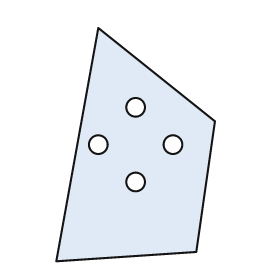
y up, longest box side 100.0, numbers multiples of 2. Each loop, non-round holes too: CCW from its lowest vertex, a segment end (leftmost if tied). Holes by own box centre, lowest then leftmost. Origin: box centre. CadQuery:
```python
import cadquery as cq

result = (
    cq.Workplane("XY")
    .moveTo(-34.0, -50.0)
    .lineTo(26.0, -46.0)
    .lineTo(34.0, 10.0)
    .lineTo(-16.0, 50.0)
    .close()
    .moveTo(0.0, -16.0)
    .circle(4.0)
    .moveTo(-16.0, 0.0)
    .circle(4.0)
    .moveTo(16.0, 0.0)
    .circle(4.0)
    .moveTo(0.0, 16.0)
    .circle(4.0)
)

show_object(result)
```